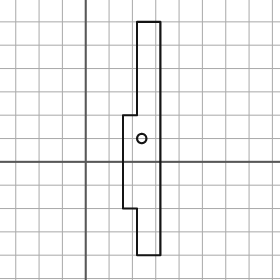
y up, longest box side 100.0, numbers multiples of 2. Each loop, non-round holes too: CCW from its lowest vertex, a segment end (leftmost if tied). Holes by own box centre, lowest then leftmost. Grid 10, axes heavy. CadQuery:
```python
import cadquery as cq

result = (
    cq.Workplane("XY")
    .moveTo(22.0, -40.0)
    .lineTo(32.0, -40.0)
    .lineTo(32.0, 60.0)
    .lineTo(22.0, 60.0)
    .lineTo(22.0, 20.0)
    .lineTo(16.0, 20.0)
    .lineTo(16.0, -20.0)
    .lineTo(22.0, -20.0)
    .close()
    .moveTo(24.0, 10.0)
    .circle(2.0)
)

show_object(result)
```